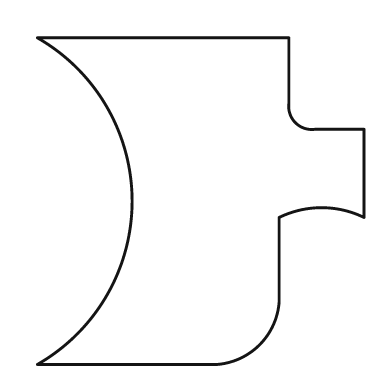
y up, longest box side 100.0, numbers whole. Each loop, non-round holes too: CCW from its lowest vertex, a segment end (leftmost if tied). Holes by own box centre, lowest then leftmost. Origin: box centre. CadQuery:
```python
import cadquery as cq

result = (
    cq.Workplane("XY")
    .moveTo(-50.0, -50.0)
    .lineTo(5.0, -50.0)
    .threePointArc((18.0, -44.0), (24.0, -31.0))
    .lineTo(24.0, -5.0)
    .threePointArc((37.0, -2.0), (50.0, -5.0))
    .lineTo(50.0, 22.0)
    .lineTo(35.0, 22.0)
    .threePointArc((29.0, 24.0), (27.0, 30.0))
    .lineTo(27.0, 50.0)
    .lineTo(-50.0, 50.0)
    .threePointArc((-21.0, 0.0), (-50.0, -50.0))
    .close()
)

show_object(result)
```